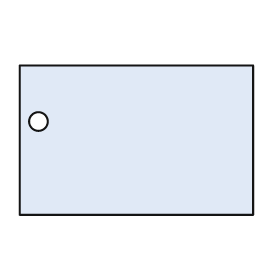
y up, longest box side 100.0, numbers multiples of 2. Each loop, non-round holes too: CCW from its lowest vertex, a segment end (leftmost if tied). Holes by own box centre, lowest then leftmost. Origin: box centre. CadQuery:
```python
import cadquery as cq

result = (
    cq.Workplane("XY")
    .moveTo(-50.0, -32.0)
    .lineTo(50.0, -32.0)
    .lineTo(50.0, 32.0)
    .lineTo(-50.0, 32.0)
    .close()
    .moveTo(-42.0, 8.0)
    .circle(4.0)
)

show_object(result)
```